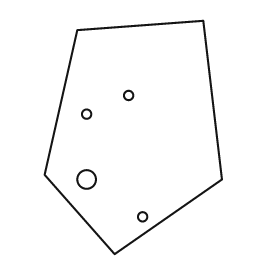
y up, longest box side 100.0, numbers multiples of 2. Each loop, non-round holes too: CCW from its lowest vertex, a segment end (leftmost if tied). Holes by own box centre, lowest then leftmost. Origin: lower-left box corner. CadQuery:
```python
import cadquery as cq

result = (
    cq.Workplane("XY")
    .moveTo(30.0, 0.0)
    .lineTo(76.0, 32.0)
    .lineTo(68.0, 100.0)
    .lineTo(14.0, 96.0)
    .lineTo(0.0, 34.0)
    .close()
    .moveTo(42.0, 16.0)
    .circle(2.0)
    .moveTo(18.0, 32.0)
    .circle(4.0)
    .moveTo(18.0, 60.0)
    .circle(2.0)
    .moveTo(36.0, 68.0)
    .circle(2.0)
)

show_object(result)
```